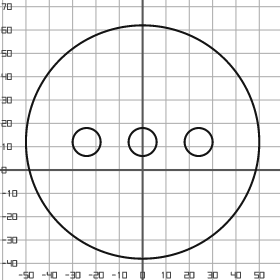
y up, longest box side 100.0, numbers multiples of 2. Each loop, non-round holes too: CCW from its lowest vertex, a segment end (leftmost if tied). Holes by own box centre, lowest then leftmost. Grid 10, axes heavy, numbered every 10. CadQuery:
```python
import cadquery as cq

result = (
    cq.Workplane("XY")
    .moveTo(0.0, 12.0)
    .circle(50.0)
    .moveTo(-24.0, 12.0)
    .circle(6.0)
    .moveTo(0.0, 12.0)
    .circle(6.0)
    .moveTo(24.0, 12.0)
    .circle(6.0)
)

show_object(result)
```